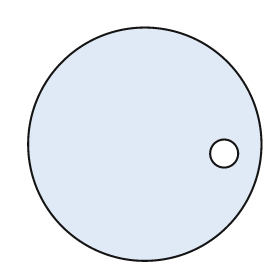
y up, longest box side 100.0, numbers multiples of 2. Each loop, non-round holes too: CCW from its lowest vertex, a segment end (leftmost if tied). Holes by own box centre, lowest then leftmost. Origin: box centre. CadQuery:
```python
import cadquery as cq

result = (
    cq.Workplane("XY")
    .moveTo(0.0, 0.0)
    .circle(50.0)
    .moveTo(34.0, -4.0)
    .circle(6.0)
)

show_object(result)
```